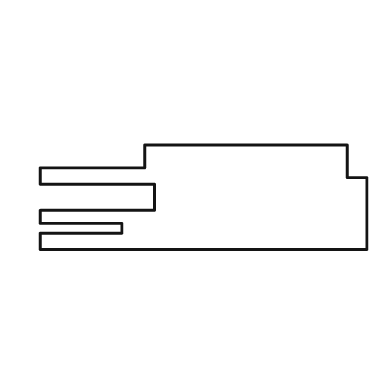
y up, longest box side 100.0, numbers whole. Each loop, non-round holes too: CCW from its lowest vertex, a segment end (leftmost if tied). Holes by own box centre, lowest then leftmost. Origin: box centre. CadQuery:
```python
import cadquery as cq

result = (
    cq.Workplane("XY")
    .moveTo(-50.0, -16.0)
    .lineTo(50.0, -16.0)
    .lineTo(50.0, 6.0)
    .lineTo(44.0, 6.0)
    .lineTo(44.0, 16.0)
    .lineTo(-18.0, 16.0)
    .lineTo(-18.0, 9.0)
    .lineTo(-50.0, 9.0)
    .lineTo(-50.0, 4.0)
    .lineTo(-15.0, 4.0)
    .lineTo(-15.0, -4.0)
    .lineTo(-50.0, -4.0)
    .lineTo(-50.0, -8.0)
    .lineTo(-25.0, -8.0)
    .lineTo(-25.0, -11.0)
    .lineTo(-50.0, -11.0)
    .close()
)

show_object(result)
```